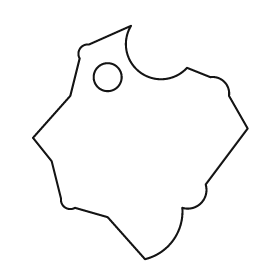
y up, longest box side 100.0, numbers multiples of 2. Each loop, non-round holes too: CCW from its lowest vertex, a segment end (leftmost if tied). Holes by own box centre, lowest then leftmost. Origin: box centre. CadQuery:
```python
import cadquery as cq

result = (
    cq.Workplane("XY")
    .moveTo(2.0, -50.0)
    .threePointArc((14.0, -42.0), (18.0, -28.0))
    .threePointArc((26.0, -26.0), (28.0, -18.0))
    .lineTo(46.0, 6.0)
    .lineTo(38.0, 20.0)
    .threePointArc((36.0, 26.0), (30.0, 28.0))
    .lineTo(20.0, 32.0)
    .threePointArc((0.0, 30.0), (-4.0, 50.0))
    .lineTo(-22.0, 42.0)
    .threePointArc((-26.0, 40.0), (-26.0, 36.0))
    .lineTo(-30.0, 20.0)
    .lineTo(-46.0, 2.0)
    .lineTo(-38.0, -8.0)
    .lineTo(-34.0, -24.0)
    .threePointArc((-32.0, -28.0), (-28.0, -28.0))
    .lineTo(-14.0, -32.0)
    .close()
    .moveTo(-14.0, 28.0)
    .circle(6.0)
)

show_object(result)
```